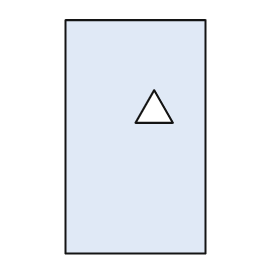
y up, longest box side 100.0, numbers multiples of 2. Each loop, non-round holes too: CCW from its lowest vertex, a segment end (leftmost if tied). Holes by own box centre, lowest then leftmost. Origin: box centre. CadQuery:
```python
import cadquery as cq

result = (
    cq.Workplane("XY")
    .moveTo(-30.0, -50.0)
    .lineTo(30.0, -50.0)
    .lineTo(30.0, 50.0)
    .lineTo(-30.0, 50.0)
    .close()
    .moveTo(0.0, 6.0)
    .lineTo(16.0, 6.0)
    .lineTo(8.0, 20.0)
    .close()
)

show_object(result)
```